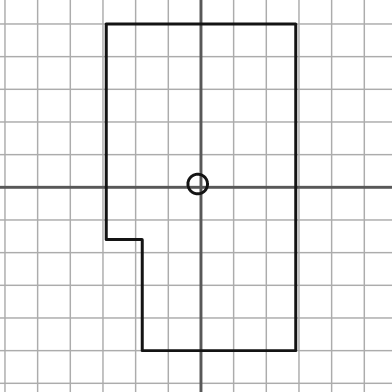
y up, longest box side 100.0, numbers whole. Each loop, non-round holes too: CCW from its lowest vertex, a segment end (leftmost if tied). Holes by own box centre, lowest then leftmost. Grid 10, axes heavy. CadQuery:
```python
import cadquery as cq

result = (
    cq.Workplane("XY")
    .moveTo(-18.0, -50.0)
    .lineTo(29.0, -50.0)
    .lineTo(29.0, 50.0)
    .lineTo(-29.0, 50.0)
    .lineTo(-29.0, -16.0)
    .lineTo(-18.0, -16.0)
    .close()
    .moveTo(-1.0, 1.0)
    .circle(3.0)
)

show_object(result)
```